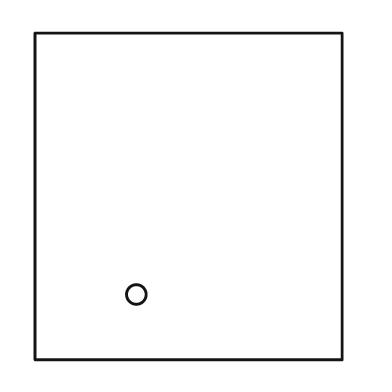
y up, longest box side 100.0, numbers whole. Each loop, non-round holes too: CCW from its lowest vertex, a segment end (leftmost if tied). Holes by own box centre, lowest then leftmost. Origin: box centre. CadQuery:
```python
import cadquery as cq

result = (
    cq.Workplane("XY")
    .moveTo(-47.0, -50.0)
    .lineTo(47.0, -50.0)
    .lineTo(47.0, 50.0)
    .lineTo(-47.0, 50.0)
    .close()
    .moveTo(-16.0, -30.0)
    .circle(3.0)
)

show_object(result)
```